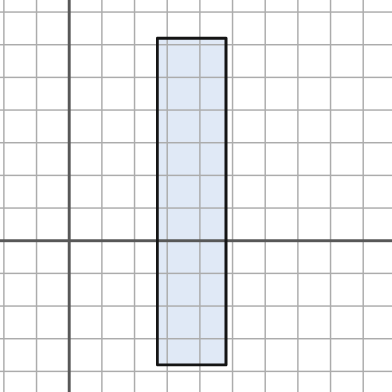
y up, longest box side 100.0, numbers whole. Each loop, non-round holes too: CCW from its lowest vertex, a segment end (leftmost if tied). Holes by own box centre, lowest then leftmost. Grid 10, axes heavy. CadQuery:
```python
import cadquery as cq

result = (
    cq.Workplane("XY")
    .moveTo(27.0, -38.0)
    .lineTo(48.0, -38.0)
    .lineTo(48.0, 62.0)
    .lineTo(27.0, 62.0)
    .close()
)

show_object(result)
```